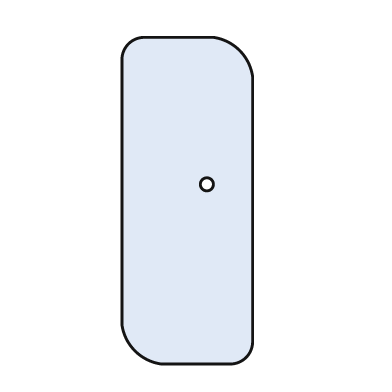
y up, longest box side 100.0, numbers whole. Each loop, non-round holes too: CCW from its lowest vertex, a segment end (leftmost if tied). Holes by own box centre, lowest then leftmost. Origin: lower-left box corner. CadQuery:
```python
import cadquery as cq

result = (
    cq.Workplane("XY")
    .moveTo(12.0, 0.0)
    .lineTo(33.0, 0.0)
    .threePointArc((38.0, 2.0), (40.0, 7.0))
    .lineTo(40.0, 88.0)
    .threePointArc((36.0, 96.0), (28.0, 100.0))
    .lineTo(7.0, 100.0)
    .threePointArc((2.0, 98.0), (0.0, 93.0))
    .lineTo(0.0, 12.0)
    .threePointArc((4.0, 4.0), (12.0, 0.0))
    .close()
    .moveTo(26.0, 55.0)
    .circle(2.0)
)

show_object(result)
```